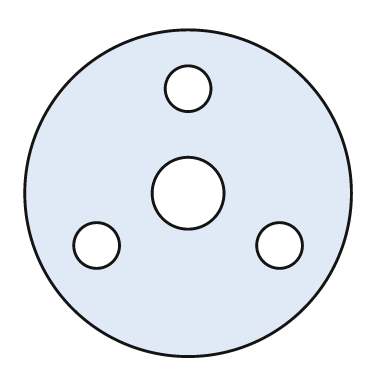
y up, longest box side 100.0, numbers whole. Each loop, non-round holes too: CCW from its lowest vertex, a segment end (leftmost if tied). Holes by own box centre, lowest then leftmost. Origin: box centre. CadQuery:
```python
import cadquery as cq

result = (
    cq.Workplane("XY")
    .moveTo(0.0, 0.0)
    .circle(50.0)
    .moveTo(-28.0, -16.0)
    .circle(7.0)
    .moveTo(28.0, -16.0)
    .circle(7.0)
    .moveTo(0.0, 0.0)
    .circle(11.0)
    .moveTo(0.0, 32.0)
    .circle(7.0)
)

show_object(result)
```